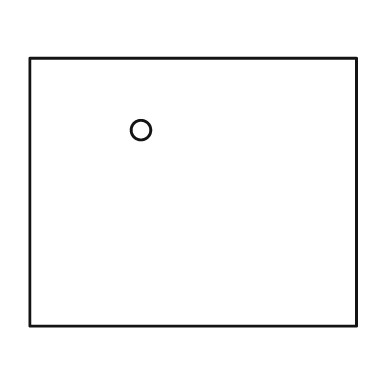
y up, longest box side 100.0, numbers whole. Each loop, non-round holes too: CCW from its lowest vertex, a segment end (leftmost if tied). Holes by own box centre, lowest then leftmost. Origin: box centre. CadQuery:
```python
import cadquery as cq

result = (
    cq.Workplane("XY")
    .moveTo(-50.0, -41.0)
    .lineTo(50.0, -41.0)
    .lineTo(50.0, 41.0)
    .lineTo(-50.0, 41.0)
    .close()
    .moveTo(-16.0, 19.0)
    .circle(3.0)
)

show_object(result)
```